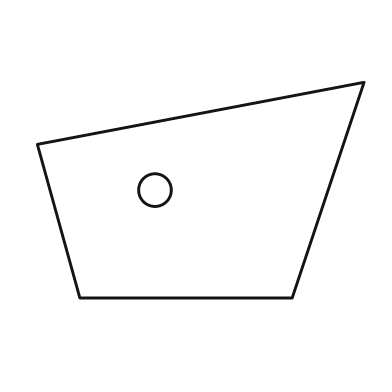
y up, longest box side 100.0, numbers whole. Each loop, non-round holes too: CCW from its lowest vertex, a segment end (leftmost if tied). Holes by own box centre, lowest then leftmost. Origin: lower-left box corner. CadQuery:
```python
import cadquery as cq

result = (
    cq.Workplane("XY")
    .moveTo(13.0, 0.0)
    .lineTo(78.0, 0.0)
    .lineTo(100.0, 66.0)
    .lineTo(0.0, 47.0)
    .close()
    .moveTo(36.0, 33.0)
    .circle(5.0)
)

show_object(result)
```